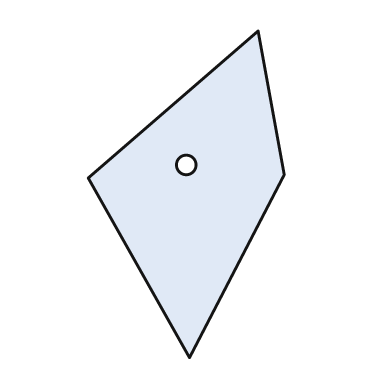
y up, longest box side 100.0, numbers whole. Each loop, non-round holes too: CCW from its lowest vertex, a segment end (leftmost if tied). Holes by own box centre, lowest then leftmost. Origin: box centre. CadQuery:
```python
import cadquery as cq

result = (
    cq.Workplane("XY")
    .moveTo(1.0, -50.0)
    .lineTo(30.0, 6.0)
    .lineTo(22.0, 50.0)
    .lineTo(-30.0, 5.0)
    .close()
    .moveTo(0.0, 9.0)
    .circle(3.0)
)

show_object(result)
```